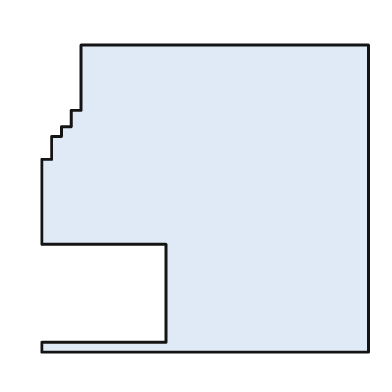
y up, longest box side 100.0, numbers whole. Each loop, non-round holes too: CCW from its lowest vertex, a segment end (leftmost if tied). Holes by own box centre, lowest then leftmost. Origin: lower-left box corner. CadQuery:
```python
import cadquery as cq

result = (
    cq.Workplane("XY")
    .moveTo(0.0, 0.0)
    .lineTo(100.0, 0.0)
    .lineTo(100.0, 94.0)
    .lineTo(12.0, 94.0)
    .lineTo(12.0, 74.0)
    .lineTo(9.0, 74.0)
    .lineTo(9.0, 69.0)
    .lineTo(6.0, 69.0)
    .lineTo(6.0, 66.0)
    .lineTo(3.0, 66.0)
    .lineTo(3.0, 59.0)
    .lineTo(0.0, 59.0)
    .lineTo(0.0, 33.0)
    .lineTo(38.0, 33.0)
    .lineTo(38.0, 3.0)
    .lineTo(0.0, 3.0)
    .close()
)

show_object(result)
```